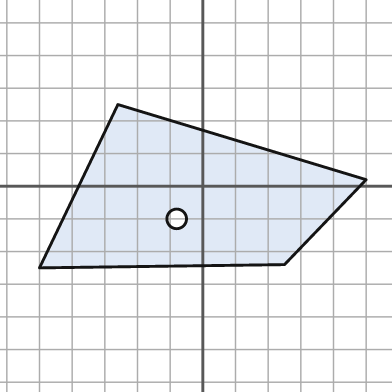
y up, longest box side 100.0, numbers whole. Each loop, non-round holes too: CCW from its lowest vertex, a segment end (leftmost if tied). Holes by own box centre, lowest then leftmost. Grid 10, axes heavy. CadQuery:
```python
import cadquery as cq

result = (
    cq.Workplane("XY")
    .moveTo(-50.0, -25.0)
    .lineTo(25.0, -24.0)
    .lineTo(50.0, 2.0)
    .lineTo(-26.0, 25.0)
    .close()
    .moveTo(-8.0, -10.0)
    .circle(3.0)
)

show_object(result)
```